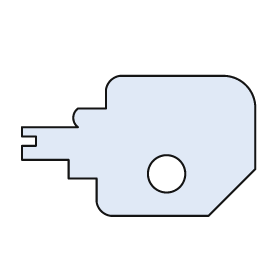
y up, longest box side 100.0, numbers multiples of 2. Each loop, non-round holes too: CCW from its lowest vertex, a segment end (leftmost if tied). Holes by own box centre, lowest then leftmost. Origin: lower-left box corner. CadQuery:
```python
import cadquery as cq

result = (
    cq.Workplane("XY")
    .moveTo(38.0, 0.0)
    .lineTo(80.0, 0.0)
    .lineTo(100.0, 20.0)
    .lineTo(100.0, 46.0)
    .threePointArc((96.0, 56.0), (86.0, 60.0))
    .lineTo(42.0, 60.0)
    .threePointArc((38.0, 58.0), (36.0, 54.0))
    .lineTo(36.0, 46.0)
    .lineTo(24.0, 46.0)
    .threePointArc((22.0, 42.0), (24.0, 38.0))
    .lineTo(0.0, 38.0)
    .lineTo(0.0, 34.0)
    .lineTo(6.0, 34.0)
    .lineTo(6.0, 30.0)
    .lineTo(0.0, 30.0)
    .lineTo(0.0, 24.0)
    .lineTo(20.0, 24.0)
    .lineTo(20.0, 16.0)
    .lineTo(32.0, 16.0)
    .lineTo(32.0, 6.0)
    .threePointArc((34.0, 2.0), (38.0, 0.0))
    .close()
    .moveTo(62.0, 18.0)
    .circle(8.0)
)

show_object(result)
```